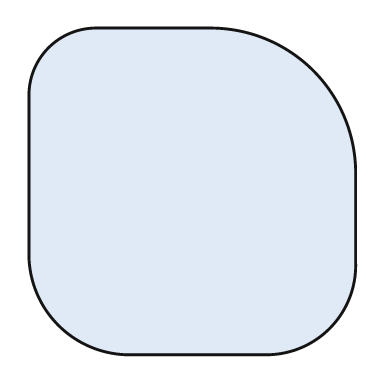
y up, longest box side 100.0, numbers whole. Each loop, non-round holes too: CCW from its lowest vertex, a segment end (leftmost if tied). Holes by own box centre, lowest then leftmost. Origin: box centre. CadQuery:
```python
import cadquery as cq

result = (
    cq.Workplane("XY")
    .moveTo(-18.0, -50.0)
    .lineTo(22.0, -50.0)
    .threePointArc((42.0, -42.0), (50.0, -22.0))
    .lineTo(50.0, 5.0)
    .threePointArc((37.0, 37.0), (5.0, 50.0))
    .lineTo(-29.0, 50.0)
    .threePointArc((-44.0, 44.0), (-50.0, 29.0))
    .lineTo(-50.0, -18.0)
    .threePointArc((-41.0, -41.0), (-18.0, -50.0))
    .close()
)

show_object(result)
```